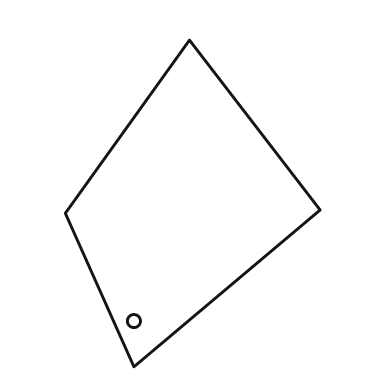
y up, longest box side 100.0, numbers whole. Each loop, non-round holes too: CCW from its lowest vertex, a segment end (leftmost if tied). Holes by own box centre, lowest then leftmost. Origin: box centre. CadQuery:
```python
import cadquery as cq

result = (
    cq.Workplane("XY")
    .moveTo(-18.0, -50.0)
    .lineTo(39.0, -2.0)
    .lineTo(-1.0, 50.0)
    .lineTo(-39.0, -3.0)
    .close()
    .moveTo(-18.0, -36.0)
    .circle(2.0)
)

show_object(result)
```